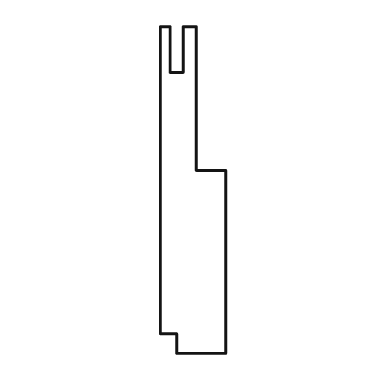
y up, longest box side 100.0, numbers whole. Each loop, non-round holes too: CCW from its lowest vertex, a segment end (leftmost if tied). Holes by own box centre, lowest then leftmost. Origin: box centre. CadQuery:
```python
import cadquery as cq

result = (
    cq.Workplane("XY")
    .moveTo(-5.0, -50.0)
    .lineTo(10.0, -50.0)
    .lineTo(10.0, 6.0)
    .lineTo(1.0, 6.0)
    .lineTo(1.0, 50.0)
    .lineTo(-3.0, 50.0)
    .lineTo(-3.0, 36.0)
    .lineTo(-7.0, 36.0)
    .lineTo(-7.0, 50.0)
    .lineTo(-10.0, 50.0)
    .lineTo(-10.0, -44.0)
    .lineTo(-5.0, -44.0)
    .close()
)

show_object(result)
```